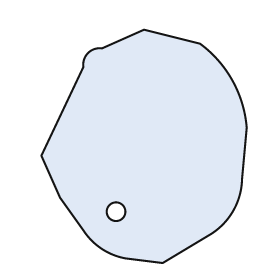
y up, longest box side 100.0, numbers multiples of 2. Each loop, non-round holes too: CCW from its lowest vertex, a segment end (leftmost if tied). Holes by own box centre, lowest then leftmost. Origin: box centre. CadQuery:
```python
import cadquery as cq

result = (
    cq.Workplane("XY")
    .moveTo(8.0, -50.0)
    .lineTo(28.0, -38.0)
    .threePointArc((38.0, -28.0), (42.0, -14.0))
    .lineTo(44.0, 8.0)
    .threePointArc((38.0, 28.0), (24.0, 44.0))
    .lineTo(0.0, 50.0)
    .lineTo(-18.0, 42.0)
    .threePointArc((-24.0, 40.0), (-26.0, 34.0))
    .lineTo(-44.0, -4.0)
    .lineTo(-36.0, -22.0)
    .lineTo(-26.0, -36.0)
    .threePointArc((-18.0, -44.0), (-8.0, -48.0))
    .close()
    .moveTo(-12.0, -28.0)
    .circle(4.0)
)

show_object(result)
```